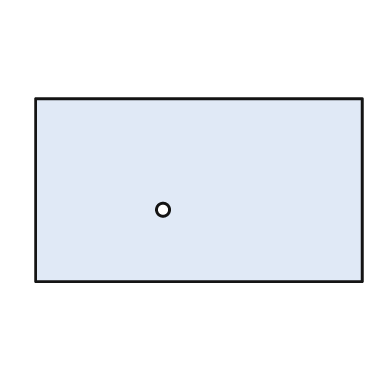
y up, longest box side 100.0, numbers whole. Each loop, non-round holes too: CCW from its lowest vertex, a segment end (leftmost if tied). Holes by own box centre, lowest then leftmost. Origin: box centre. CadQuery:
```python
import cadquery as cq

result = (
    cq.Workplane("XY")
    .moveTo(-50.0, -28.0)
    .lineTo(50.0, -28.0)
    .lineTo(50.0, 28.0)
    .lineTo(-50.0, 28.0)
    .close()
    .moveTo(-11.0, -6.0)
    .circle(2.0)
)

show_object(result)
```